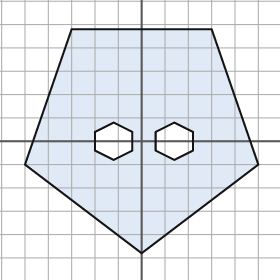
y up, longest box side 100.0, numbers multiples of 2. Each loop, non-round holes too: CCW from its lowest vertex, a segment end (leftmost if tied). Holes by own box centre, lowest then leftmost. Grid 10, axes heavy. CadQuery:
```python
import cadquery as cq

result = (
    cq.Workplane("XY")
    .moveTo(0.0, -48.0)
    .lineTo(50.0, -10.0)
    .lineTo(30.0, 48.0)
    .lineTo(-30.0, 48.0)
    .lineTo(-50.0, -10.0)
    .close()
    .moveTo(-12.0, -8.0)
    .lineTo(-4.0, -4.0)
    .lineTo(-4.0, 4.0)
    .lineTo(-12.0, 8.0)
    .lineTo(-20.0, 4.0)
    .lineTo(-20.0, -4.0)
    .close()
    .moveTo(14.0, -8.0)
    .lineTo(22.0, -4.0)
    .lineTo(22.0, 4.0)
    .lineTo(14.0, 8.0)
    .lineTo(6.0, 4.0)
    .lineTo(6.0, -4.0)
    .close()
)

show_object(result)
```